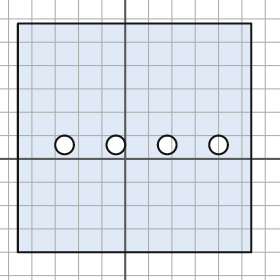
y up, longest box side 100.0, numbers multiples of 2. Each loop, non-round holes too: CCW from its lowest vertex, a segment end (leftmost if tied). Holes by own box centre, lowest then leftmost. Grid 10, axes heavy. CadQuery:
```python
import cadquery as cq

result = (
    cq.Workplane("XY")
    .moveTo(-46.0, -40.0)
    .lineTo(54.0, -40.0)
    .lineTo(54.0, 58.0)
    .lineTo(-46.0, 58.0)
    .close()
    .moveTo(-26.0, 6.0)
    .circle(4.0)
    .moveTo(-4.0, 6.0)
    .circle(4.0)
    .moveTo(18.0, 6.0)
    .circle(4.0)
    .moveTo(40.0, 6.0)
    .circle(4.0)
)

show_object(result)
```